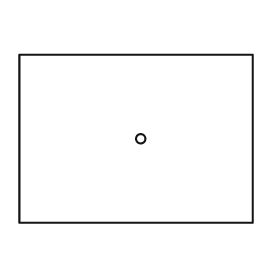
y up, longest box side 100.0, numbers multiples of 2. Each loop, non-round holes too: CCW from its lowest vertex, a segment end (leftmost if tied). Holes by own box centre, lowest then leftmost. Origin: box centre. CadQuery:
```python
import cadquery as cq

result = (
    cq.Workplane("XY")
    .moveTo(-50.0, -36.0)
    .lineTo(50.0, -36.0)
    .lineTo(50.0, 36.0)
    .lineTo(-50.0, 36.0)
    .close()
    .moveTo(2.0, 0.0)
    .circle(2.0)
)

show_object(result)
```